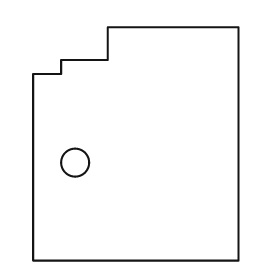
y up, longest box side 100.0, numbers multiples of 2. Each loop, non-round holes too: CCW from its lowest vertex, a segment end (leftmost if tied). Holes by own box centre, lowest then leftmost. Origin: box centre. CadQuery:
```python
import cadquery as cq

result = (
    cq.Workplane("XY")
    .moveTo(-44.0, -50.0)
    .lineTo(44.0, -50.0)
    .lineTo(44.0, 50.0)
    .lineTo(-12.0, 50.0)
    .lineTo(-12.0, 36.0)
    .lineTo(-32.0, 36.0)
    .lineTo(-32.0, 30.0)
    .lineTo(-44.0, 30.0)
    .close()
    .moveTo(-26.0, -8.0)
    .circle(6.0)
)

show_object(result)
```